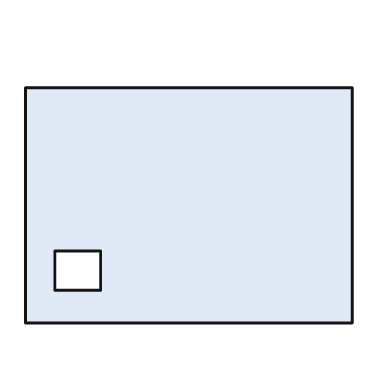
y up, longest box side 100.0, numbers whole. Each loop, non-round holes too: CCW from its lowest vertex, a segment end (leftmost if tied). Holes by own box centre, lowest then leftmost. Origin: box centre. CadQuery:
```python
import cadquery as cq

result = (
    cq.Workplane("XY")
    .moveTo(-50.0, -36.0)
    .lineTo(50.0, -36.0)
    .lineTo(50.0, 36.0)
    .lineTo(-50.0, 36.0)
    .close()
    .moveTo(-41.0, -26.0)
    .lineTo(-27.0, -26.0)
    .lineTo(-27.0, -14.0)
    .lineTo(-41.0, -14.0)
    .close()
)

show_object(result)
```